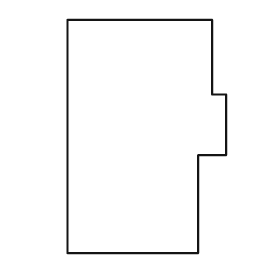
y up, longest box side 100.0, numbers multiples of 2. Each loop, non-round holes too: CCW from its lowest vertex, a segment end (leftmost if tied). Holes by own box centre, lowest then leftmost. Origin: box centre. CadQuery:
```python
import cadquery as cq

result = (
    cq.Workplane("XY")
    .moveTo(-34.0, -50.0)
    .lineTo(22.0, -50.0)
    .lineTo(22.0, -8.0)
    .lineTo(34.0, -8.0)
    .lineTo(34.0, 18.0)
    .lineTo(28.0, 18.0)
    .lineTo(28.0, 50.0)
    .lineTo(-34.0, 50.0)
    .close()
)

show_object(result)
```